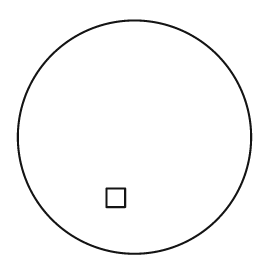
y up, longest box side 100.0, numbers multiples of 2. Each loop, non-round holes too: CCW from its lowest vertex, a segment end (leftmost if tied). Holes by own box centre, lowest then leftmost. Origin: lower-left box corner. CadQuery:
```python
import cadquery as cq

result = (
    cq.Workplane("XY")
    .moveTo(50.0, 50.0)
    .circle(50.0)
    .moveTo(38.0, 20.0)
    .lineTo(46.0, 20.0)
    .lineTo(46.0, 28.0)
    .lineTo(38.0, 28.0)
    .close()
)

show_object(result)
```